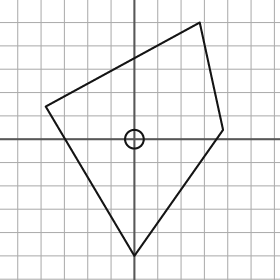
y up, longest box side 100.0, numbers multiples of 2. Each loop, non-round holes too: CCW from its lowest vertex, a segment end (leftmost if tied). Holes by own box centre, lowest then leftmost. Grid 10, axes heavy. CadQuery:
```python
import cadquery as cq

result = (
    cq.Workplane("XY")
    .moveTo(0.0, -50.0)
    .lineTo(38.0, 4.0)
    .lineTo(28.0, 50.0)
    .lineTo(-38.0, 14.0)
    .close()
    .moveTo(0.0, 0.0)
    .circle(4.0)
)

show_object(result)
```